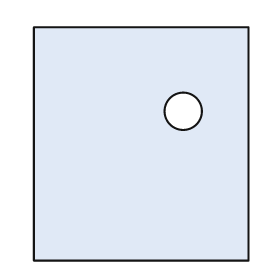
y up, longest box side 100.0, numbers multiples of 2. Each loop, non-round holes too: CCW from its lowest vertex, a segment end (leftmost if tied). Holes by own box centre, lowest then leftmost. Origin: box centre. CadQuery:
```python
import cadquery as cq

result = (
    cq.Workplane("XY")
    .moveTo(-46.0, -50.0)
    .lineTo(46.0, -50.0)
    .lineTo(46.0, 50.0)
    .lineTo(-46.0, 50.0)
    .close()
    .moveTo(18.0, 14.0)
    .circle(8.0)
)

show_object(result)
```